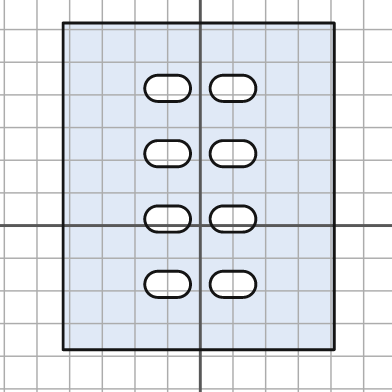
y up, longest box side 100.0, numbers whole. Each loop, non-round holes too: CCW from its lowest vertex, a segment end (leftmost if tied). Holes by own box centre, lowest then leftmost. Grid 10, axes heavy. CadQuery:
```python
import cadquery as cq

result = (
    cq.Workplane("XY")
    .moveTo(-42.0, -38.0)
    .lineTo(41.0, -38.0)
    .lineTo(41.0, 62.0)
    .lineTo(-42.0, 62.0)
    .close()
    .moveTo(-13.0, -22.0)
    .lineTo(-7.0, -22.0)
    .threePointArc((-3.0, -18.0), (-7.0, -14.0))
    .lineTo(-13.0, -14.0)
    .threePointArc((-17.0, -18.0), (-13.0, -22.0))
    .close()
    .moveTo(7.0, -22.0)
    .lineTo(13.0, -22.0)
    .threePointArc((17.0, -18.0), (13.0, -14.0))
    .lineTo(7.0, -14.0)
    .threePointArc((3.0, -18.0), (7.0, -22.0))
    .close()
    .moveTo(-13.0, -2.0)
    .lineTo(-7.0, -2.0)
    .threePointArc((-3.0, 2.0), (-7.0, 6.0))
    .lineTo(-13.0, 6.0)
    .threePointArc((-17.0, 2.0), (-13.0, -2.0))
    .close()
    .moveTo(7.0, -2.0)
    .lineTo(13.0, -2.0)
    .threePointArc((17.0, 2.0), (13.0, 6.0))
    .lineTo(7.0, 6.0)
    .threePointArc((3.0, 2.0), (7.0, -2.0))
    .close()
    .moveTo(-13.0, 18.0)
    .lineTo(-7.0, 18.0)
    .threePointArc((-3.0, 22.0), (-7.0, 26.0))
    .lineTo(-13.0, 26.0)
    .threePointArc((-17.0, 22.0), (-13.0, 18.0))
    .close()
    .moveTo(7.0, 18.0)
    .lineTo(13.0, 18.0)
    .threePointArc((17.0, 22.0), (13.0, 26.0))
    .lineTo(7.0, 26.0)
    .threePointArc((3.0, 22.0), (7.0, 18.0))
    .close()
    .moveTo(-13.0, 38.0)
    .lineTo(-7.0, 38.0)
    .threePointArc((-3.0, 42.0), (-7.0, 46.0))
    .lineTo(-13.0, 46.0)
    .threePointArc((-17.0, 42.0), (-13.0, 38.0))
    .close()
    .moveTo(7.0, 38.0)
    .lineTo(13.0, 38.0)
    .threePointArc((17.0, 42.0), (13.0, 46.0))
    .lineTo(7.0, 46.0)
    .threePointArc((3.0, 42.0), (7.0, 38.0))
    .close()
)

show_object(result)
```